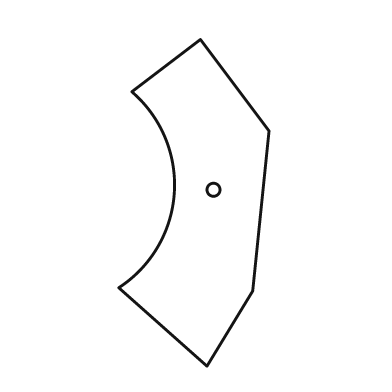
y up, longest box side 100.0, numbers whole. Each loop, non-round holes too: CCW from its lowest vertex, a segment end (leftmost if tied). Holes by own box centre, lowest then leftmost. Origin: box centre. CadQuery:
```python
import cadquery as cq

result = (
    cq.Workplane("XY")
    .moveTo(4.0, -50.0)
    .lineTo(18.0, -27.0)
    .lineTo(23.0, 22.0)
    .lineTo(2.0, 50.0)
    .lineTo(-19.0, 34.0)
    .threePointArc((-6.0, 3.0), (-23.0, -26.0))
    .close()
    .moveTo(6.0, 4.0)
    .circle(2.0)
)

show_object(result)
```